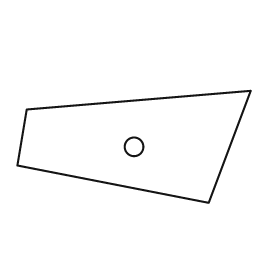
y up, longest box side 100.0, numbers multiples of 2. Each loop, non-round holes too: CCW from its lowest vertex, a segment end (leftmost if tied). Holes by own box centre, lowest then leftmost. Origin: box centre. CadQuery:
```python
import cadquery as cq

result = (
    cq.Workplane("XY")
    .moveTo(32.0, -24.0)
    .lineTo(50.0, 24.0)
    .lineTo(-46.0, 16.0)
    .lineTo(-50.0, -8.0)
    .close()
    .moveTo(0.0, 0.0)
    .circle(4.0)
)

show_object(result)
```